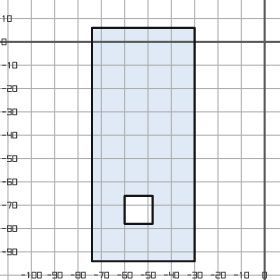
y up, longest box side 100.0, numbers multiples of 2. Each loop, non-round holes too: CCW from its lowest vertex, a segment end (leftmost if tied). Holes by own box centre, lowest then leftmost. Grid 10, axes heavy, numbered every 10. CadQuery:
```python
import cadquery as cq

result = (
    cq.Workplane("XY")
    .moveTo(-74.0, -94.0)
    .lineTo(-30.0, -94.0)
    .lineTo(-30.0, 6.0)
    .lineTo(-74.0, 6.0)
    .close()
    .moveTo(-60.0, -78.0)
    .lineTo(-48.0, -78.0)
    .lineTo(-48.0, -66.0)
    .lineTo(-60.0, -66.0)
    .close()
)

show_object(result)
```